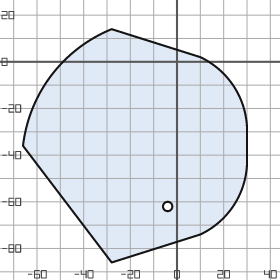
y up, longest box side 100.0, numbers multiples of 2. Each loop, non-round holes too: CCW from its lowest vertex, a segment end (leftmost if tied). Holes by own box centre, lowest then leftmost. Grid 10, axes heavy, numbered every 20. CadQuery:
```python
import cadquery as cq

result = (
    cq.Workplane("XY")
    .moveTo(-28.0, -86.0)
    .lineTo(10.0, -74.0)
    .threePointArc((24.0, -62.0), (30.0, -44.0))
    .lineTo(30.0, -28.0)
    .threePointArc((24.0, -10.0), (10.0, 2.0))
    .lineTo(-28.0, 14.0)
    .threePointArc((-54.0, -6.0), (-66.0, -36.0))
    .close()
    .moveTo(-4.0, -62.0)
    .circle(2.0)
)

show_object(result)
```